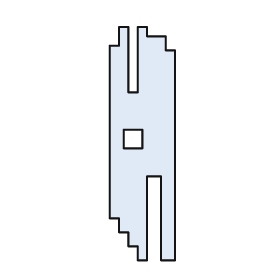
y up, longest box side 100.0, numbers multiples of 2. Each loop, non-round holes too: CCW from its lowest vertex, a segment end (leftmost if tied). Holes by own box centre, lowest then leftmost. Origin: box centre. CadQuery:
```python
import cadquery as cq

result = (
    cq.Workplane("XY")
    .moveTo(-2.0, -50.0)
    .lineTo(2.0, -50.0)
    .lineTo(2.0, -14.0)
    .lineTo(8.0, -14.0)
    .lineTo(8.0, -50.0)
    .lineTo(14.0, -50.0)
    .lineTo(14.0, 40.0)
    .lineTo(10.0, 40.0)
    .lineTo(10.0, 46.0)
    .lineTo(2.0, 46.0)
    .lineTo(2.0, 50.0)
    .lineTo(-2.0, 50.0)
    .lineTo(-2.0, 22.0)
    .lineTo(-6.0, 22.0)
    .lineTo(-6.0, 50.0)
    .lineTo(-10.0, 50.0)
    .lineTo(-10.0, 42.0)
    .lineTo(-14.0, 42.0)
    .lineTo(-14.0, -32.0)
    .lineTo(-10.0, -32.0)
    .lineTo(-10.0, -38.0)
    .lineTo(-6.0, -38.0)
    .lineTo(-6.0, -44.0)
    .lineTo(-2.0, -44.0)
    .close()
    .moveTo(-8.0, -2.0)
    .lineTo(0.0, -2.0)
    .lineTo(0.0, 6.0)
    .lineTo(-8.0, 6.0)
    .close()
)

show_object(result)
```